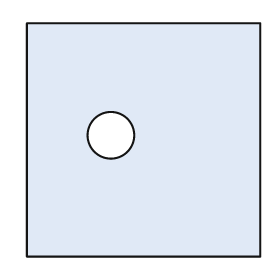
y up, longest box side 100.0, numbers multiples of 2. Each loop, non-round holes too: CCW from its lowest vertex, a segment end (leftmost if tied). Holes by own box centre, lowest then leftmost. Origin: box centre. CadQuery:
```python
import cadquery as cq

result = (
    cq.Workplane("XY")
    .moveTo(-50.0, -50.0)
    .lineTo(50.0, -50.0)
    .lineTo(50.0, 50.0)
    .lineTo(-50.0, 50.0)
    .close()
    .moveTo(-14.0, 2.0)
    .circle(10.0)
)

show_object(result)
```